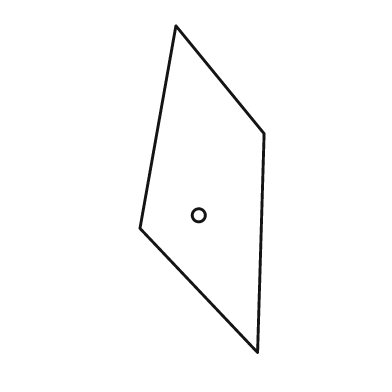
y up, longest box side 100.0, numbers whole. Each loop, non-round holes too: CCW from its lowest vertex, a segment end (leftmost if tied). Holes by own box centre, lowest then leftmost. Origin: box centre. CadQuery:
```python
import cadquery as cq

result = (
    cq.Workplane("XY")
    .moveTo(17.0, -50.0)
    .lineTo(19.0, 17.0)
    .lineTo(-8.0, 50.0)
    .lineTo(-19.0, -12.0)
    .close()
    .moveTo(-1.0, -8.0)
    .circle(2.0)
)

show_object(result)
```